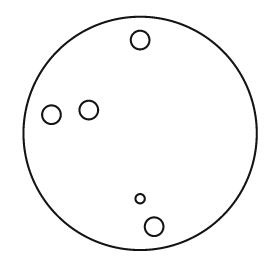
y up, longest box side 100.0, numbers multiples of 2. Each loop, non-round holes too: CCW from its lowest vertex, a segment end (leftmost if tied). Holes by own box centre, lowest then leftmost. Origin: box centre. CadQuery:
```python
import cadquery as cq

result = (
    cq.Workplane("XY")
    .moveTo(0.0, 0.0)
    .circle(50.0)
    .moveTo(6.0, -40.0)
    .circle(4.0)
    .moveTo(0.0, -28.0)
    .circle(2.0)
    .moveTo(-38.0, 8.0)
    .circle(4.0)
    .moveTo(-22.0, 10.0)
    .circle(4.0)
    .moveTo(0.0, 40.0)
    .circle(4.0)
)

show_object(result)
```